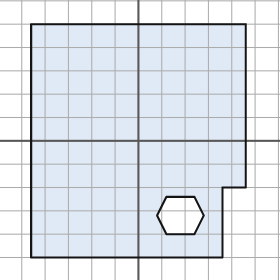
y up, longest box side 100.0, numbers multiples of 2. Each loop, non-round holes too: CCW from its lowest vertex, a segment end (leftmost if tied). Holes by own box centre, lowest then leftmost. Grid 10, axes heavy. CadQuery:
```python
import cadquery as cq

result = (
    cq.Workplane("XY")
    .moveTo(-46.0, -50.0)
    .lineTo(36.0, -50.0)
    .lineTo(36.0, -20.0)
    .lineTo(46.0, -20.0)
    .lineTo(46.0, 50.0)
    .lineTo(-46.0, 50.0)
    .close()
    .moveTo(12.0, -40.0)
    .lineTo(24.0, -40.0)
    .lineTo(28.0, -32.0)
    .lineTo(24.0, -24.0)
    .lineTo(12.0, -24.0)
    .lineTo(8.0, -32.0)
    .close()
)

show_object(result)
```